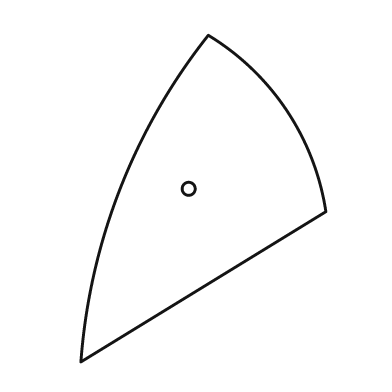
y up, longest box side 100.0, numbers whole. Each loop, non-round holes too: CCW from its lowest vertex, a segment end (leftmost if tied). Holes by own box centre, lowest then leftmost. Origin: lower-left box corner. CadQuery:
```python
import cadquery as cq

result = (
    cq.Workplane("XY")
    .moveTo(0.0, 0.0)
    .lineTo(75.0, 46.0)
    .threePointArc((63.0, 77.0), (39.0, 100.0))
    .threePointArc((12.0, 53.0), (0.0, 0.0))
    .close()
    .moveTo(33.0, 53.0)
    .circle(2.0)
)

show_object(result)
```